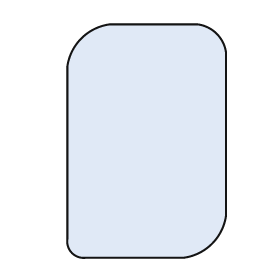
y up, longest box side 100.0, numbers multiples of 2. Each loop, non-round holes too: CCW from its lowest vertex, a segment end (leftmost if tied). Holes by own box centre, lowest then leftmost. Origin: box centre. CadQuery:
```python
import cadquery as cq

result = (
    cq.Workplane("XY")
    .moveTo(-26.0, -50.0)
    .lineTo(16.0, -50.0)
    .threePointArc((28.0, -44.0), (34.0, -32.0))
    .lineTo(34.0, 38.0)
    .threePointArc((30.0, 46.0), (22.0, 50.0))
    .lineTo(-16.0, 50.0)
    .threePointArc((-28.0, 44.0), (-34.0, 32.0))
    .lineTo(-34.0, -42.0)
    .threePointArc((-32.0, -48.0), (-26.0, -50.0))
    .close()
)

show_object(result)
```